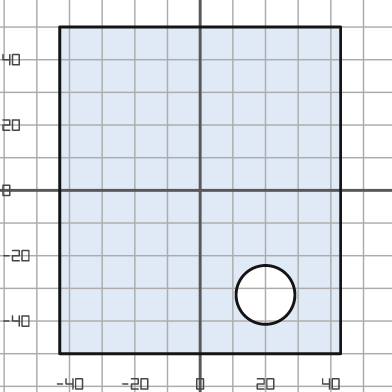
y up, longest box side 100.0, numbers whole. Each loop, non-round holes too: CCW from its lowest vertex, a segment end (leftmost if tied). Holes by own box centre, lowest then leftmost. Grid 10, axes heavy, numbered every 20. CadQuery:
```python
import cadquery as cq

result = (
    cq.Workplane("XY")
    .moveTo(-43.0, -50.0)
    .lineTo(43.0, -50.0)
    .lineTo(43.0, 50.0)
    .lineTo(-43.0, 50.0)
    .close()
    .moveTo(20.0, -32.0)
    .circle(9.0)
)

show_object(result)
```